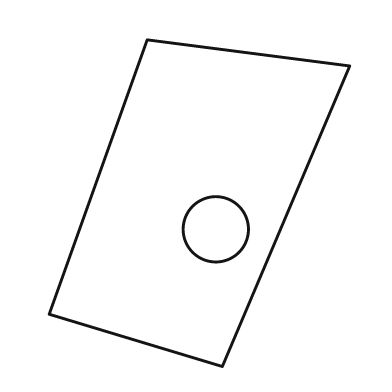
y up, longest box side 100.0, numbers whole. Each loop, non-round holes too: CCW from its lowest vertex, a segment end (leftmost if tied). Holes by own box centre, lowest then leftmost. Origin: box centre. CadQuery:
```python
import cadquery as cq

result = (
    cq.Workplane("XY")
    .moveTo(7.0, -50.0)
    .lineTo(46.0, 42.0)
    .lineTo(-16.0, 50.0)
    .lineTo(-46.0, -34.0)
    .close()
    .moveTo(5.0, -8.0)
    .circle(10.0)
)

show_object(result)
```